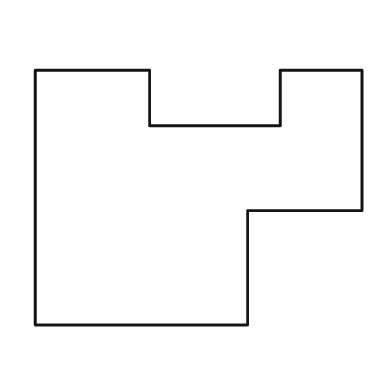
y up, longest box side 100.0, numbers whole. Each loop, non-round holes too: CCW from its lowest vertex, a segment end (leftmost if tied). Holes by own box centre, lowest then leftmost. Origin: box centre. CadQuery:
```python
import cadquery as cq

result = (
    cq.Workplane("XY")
    .moveTo(-50.0, -39.0)
    .lineTo(15.0, -39.0)
    .lineTo(15.0, -4.0)
    .lineTo(50.0, -4.0)
    .lineTo(50.0, 39.0)
    .lineTo(25.0, 39.0)
    .lineTo(25.0, 22.0)
    .lineTo(-15.0, 22.0)
    .lineTo(-15.0, 39.0)
    .lineTo(-50.0, 39.0)
    .close()
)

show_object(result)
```